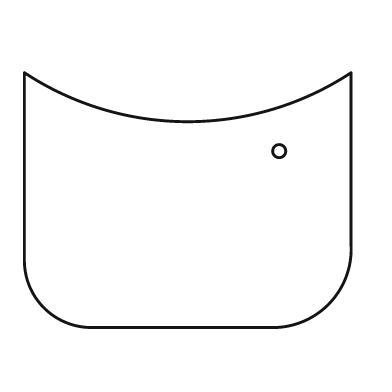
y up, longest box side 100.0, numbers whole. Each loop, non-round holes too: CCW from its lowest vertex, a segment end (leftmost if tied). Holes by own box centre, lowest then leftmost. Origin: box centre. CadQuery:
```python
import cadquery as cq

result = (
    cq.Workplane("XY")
    .moveTo(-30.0, -39.0)
    .lineTo(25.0, -39.0)
    .threePointArc((43.0, -32.0), (50.0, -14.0))
    .lineTo(50.0, 39.0)
    .threePointArc((0.0, 24.0), (-50.0, 39.0))
    .lineTo(-50.0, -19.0)
    .threePointArc((-44.0, -33.0), (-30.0, -39.0))
    .close()
    .moveTo(28.0, 15.0)
    .circle(2.0)
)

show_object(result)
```